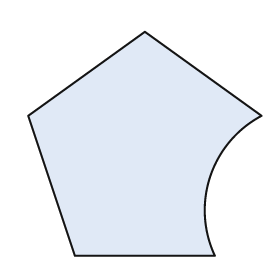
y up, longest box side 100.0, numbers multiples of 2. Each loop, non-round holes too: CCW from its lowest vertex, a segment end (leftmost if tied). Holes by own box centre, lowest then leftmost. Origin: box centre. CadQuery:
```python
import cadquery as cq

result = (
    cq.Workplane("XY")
    .moveTo(-30.0, -48.0)
    .lineTo(30.0, -48.0)
    .threePointArc((28.0, -14.0), (50.0, 12.0))
    .lineTo(0.0, 48.0)
    .lineTo(-50.0, 12.0)
    .close()
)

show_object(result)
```